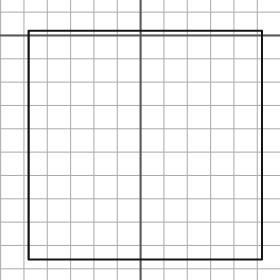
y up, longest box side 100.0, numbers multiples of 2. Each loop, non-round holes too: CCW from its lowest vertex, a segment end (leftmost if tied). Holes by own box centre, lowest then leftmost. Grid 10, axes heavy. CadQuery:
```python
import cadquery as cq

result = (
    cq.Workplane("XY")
    .moveTo(-48.0, -96.0)
    .lineTo(52.0, -96.0)
    .lineTo(52.0, 2.0)
    .lineTo(-48.0, 2.0)
    .close()
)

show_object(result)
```